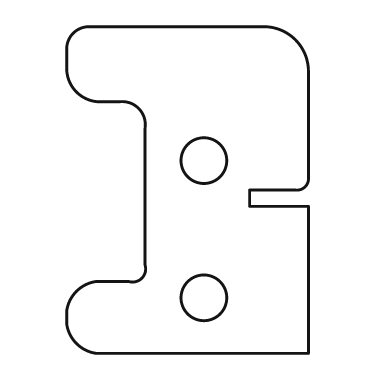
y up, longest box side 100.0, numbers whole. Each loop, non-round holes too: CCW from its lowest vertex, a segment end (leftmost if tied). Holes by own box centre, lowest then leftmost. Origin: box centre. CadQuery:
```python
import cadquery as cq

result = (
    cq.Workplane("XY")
    .moveTo(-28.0, -50.0)
    .lineTo(37.0, -50.0)
    .lineTo(37.0, -5.0)
    .lineTo(19.0, -5.0)
    .lineTo(19.0, 0.0)
    .lineTo(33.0, 0.0)
    .threePointArc((36.0, 1.0), (37.0, 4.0))
    .lineTo(37.0, 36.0)
    .threePointArc((33.0, 46.0), (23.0, 50.0))
    .lineTo(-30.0, 50.0)
    .threePointArc((-35.0, 48.0), (-37.0, 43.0))
    .lineTo(-37.0, 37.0)
    .threePointArc((-34.0, 30.0), (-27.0, 27.0))
    .lineTo(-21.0, 27.0)
    .threePointArc((-15.0, 25.0), (-13.0, 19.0))
    .lineTo(-13.0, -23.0)
    .threePointArc((-14.0, -27.0), (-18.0, -28.0))
    .lineTo(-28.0, -28.0)
    .threePointArc((-34.0, -31.0), (-37.0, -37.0))
    .lineTo(-37.0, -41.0)
    .threePointArc((-34.0, -47.0), (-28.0, -50.0))
    .close()
    .moveTo(5.0, -33.0)
    .circle(7.0)
    .moveTo(5.0, 9.0)
    .circle(7.0)
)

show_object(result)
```